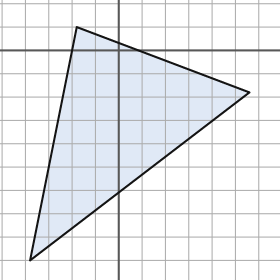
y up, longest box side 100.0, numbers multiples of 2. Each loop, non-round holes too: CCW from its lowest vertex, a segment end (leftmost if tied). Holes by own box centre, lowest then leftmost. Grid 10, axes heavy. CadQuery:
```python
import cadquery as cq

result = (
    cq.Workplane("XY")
    .moveTo(-38.0, -90.0)
    .lineTo(56.0, -18.0)
    .lineTo(-18.0, 10.0)
    .close()
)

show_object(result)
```